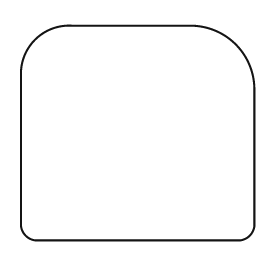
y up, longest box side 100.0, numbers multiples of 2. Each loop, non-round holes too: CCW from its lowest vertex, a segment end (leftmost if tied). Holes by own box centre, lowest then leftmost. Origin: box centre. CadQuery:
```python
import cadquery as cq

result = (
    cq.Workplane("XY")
    .moveTo(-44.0, -46.0)
    .lineTo(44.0, -46.0)
    .threePointArc((48.0, -44.0), (50.0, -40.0))
    .lineTo(50.0, 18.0)
    .threePointArc((42.0, 38.0), (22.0, 46.0))
    .lineTo(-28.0, 46.0)
    .threePointArc((-44.0, 40.0), (-50.0, 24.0))
    .lineTo(-50.0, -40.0)
    .threePointArc((-48.0, -44.0), (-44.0, -46.0))
    .close()
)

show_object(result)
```